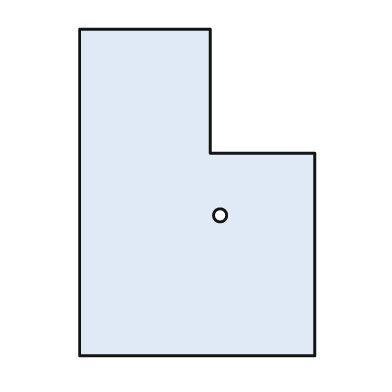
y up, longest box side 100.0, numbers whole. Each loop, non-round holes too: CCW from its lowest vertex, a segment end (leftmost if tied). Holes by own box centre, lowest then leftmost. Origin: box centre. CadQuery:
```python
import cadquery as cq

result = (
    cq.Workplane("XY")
    .moveTo(-36.0, -50.0)
    .lineTo(36.0, -50.0)
    .lineTo(36.0, 12.0)
    .lineTo(4.0, 12.0)
    .lineTo(4.0, 50.0)
    .lineTo(-36.0, 50.0)
    .close()
    .moveTo(7.0, -7.0)
    .circle(2.0)
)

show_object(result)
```